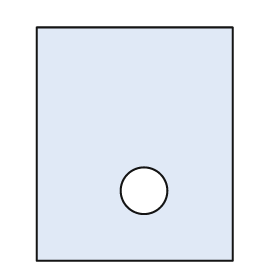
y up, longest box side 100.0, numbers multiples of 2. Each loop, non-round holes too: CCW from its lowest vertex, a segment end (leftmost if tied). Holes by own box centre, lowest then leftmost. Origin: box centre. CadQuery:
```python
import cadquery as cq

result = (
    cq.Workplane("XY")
    .moveTo(-42.0, -50.0)
    .lineTo(42.0, -50.0)
    .lineTo(42.0, 50.0)
    .lineTo(-42.0, 50.0)
    .close()
    .moveTo(4.0, -20.0)
    .circle(10.0)
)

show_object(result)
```